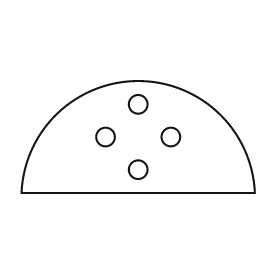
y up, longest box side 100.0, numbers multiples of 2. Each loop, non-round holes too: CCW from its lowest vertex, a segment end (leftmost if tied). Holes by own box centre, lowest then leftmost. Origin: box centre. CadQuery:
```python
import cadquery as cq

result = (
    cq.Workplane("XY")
    .moveTo(-50.0, -24.0)
    .lineTo(50.0, -24.0)
    .threePointArc((0.0, 24.0), (-50.0, -24.0))
    .close()
    .moveTo(0.0, -14.0)
    .circle(4.0)
    .moveTo(-14.0, 0.0)
    .circle(4.0)
    .moveTo(14.0, 0.0)
    .circle(4.0)
    .moveTo(0.0, 14.0)
    .circle(4.0)
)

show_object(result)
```